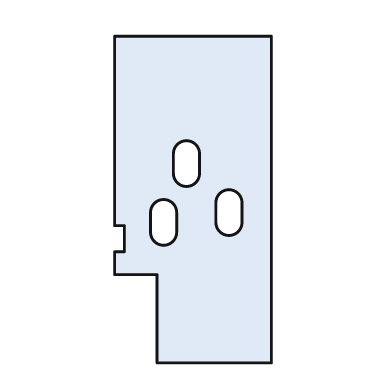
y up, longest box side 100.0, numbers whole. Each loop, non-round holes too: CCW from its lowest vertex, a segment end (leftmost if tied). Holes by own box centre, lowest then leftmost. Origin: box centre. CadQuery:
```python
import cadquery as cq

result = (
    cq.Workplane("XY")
    .moveTo(-11.0, -50.0)
    .lineTo(24.0, -50.0)
    .lineTo(24.0, 50.0)
    .lineTo(-24.0, 50.0)
    .lineTo(-24.0, -8.0)
    .lineTo(-21.0, -8.0)
    .lineTo(-21.0, -16.0)
    .lineTo(-24.0, -16.0)
    .lineTo(-24.0, -23.0)
    .lineTo(-11.0, -23.0)
    .close()
    .moveTo(-13.0, -10.0)
    .threePointArc((-9.0, -14.0), (-5.0, -10.0))
    .lineTo(-5.0, -4.0)
    .threePointArc((-9.0, 0.0), (-13.0, -4.0))
    .close()
    .moveTo(7.0, -7.0)
    .threePointArc((11.0, -11.0), (15.0, -7.0))
    .lineTo(15.0, -1.0)
    .threePointArc((11.0, 3.0), (7.0, -1.0))
    .close()
    .moveTo(-6.0, 8.0)
    .threePointArc((-2.0, 4.0), (2.0, 8.0))
    .lineTo(2.0, 14.0)
    .threePointArc((-2.0, 18.0), (-6.0, 14.0))
    .close()
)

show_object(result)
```